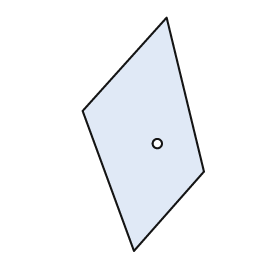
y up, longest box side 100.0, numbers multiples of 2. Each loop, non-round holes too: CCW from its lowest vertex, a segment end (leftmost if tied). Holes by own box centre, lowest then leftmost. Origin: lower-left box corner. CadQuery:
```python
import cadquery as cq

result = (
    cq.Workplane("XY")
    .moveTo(22.0, 0.0)
    .lineTo(52.0, 34.0)
    .lineTo(36.0, 100.0)
    .lineTo(0.0, 60.0)
    .close()
    .moveTo(32.0, 46.0)
    .circle(2.0)
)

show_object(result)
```